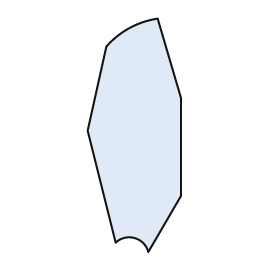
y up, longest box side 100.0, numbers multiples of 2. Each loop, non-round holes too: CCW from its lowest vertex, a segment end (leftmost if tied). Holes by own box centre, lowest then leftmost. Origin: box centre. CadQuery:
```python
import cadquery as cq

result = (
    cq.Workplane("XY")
    .moveTo(6.0, -50.0)
    .lineTo(20.0, -26.0)
    .lineTo(20.0, 16.0)
    .lineTo(10.0, 50.0)
    .threePointArc((-2.0, 46.0), (-12.0, 38.0))
    .lineTo(-20.0, 2.0)
    .lineTo(-8.0, -46.0)
    .threePointArc((0.0, -44.0), (6.0, -50.0))
    .close()
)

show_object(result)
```